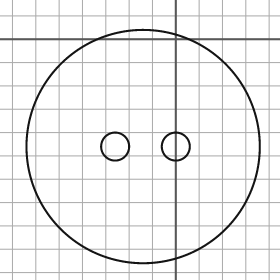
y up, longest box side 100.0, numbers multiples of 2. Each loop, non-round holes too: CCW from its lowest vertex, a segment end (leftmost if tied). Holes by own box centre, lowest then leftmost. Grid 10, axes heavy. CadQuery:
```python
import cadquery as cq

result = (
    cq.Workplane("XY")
    .moveTo(-14.0, -46.0)
    .circle(50.0)
    .moveTo(-26.0, -46.0)
    .circle(6.0)
    .moveTo(0.0, -46.0)
    .circle(6.0)
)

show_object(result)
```